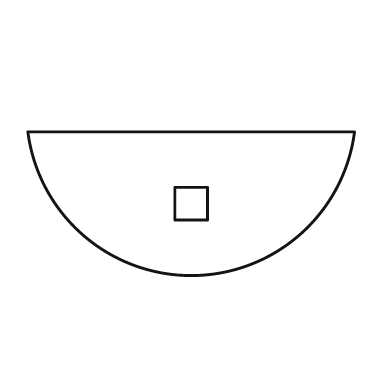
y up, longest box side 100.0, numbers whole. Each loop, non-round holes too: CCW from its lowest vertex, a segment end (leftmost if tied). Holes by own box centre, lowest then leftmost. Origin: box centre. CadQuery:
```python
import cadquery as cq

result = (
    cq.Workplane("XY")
    .moveTo(-50.0, 22.0)
    .threePointArc((0.0, -22.0), (50.0, 22.0))
    .close()
    .moveTo(-5.0, -5.0)
    .lineTo(5.0, -5.0)
    .lineTo(5.0, 5.0)
    .lineTo(-5.0, 5.0)
    .close()
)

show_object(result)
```